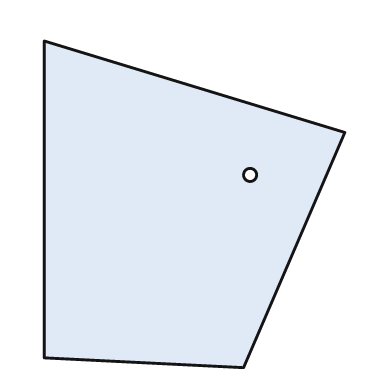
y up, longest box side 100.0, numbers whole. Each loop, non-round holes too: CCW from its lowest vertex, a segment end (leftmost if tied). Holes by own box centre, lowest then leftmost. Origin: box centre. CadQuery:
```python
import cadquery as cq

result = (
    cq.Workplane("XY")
    .moveTo(15.0, -50.0)
    .lineTo(46.0, 22.0)
    .lineTo(-46.0, 50.0)
    .lineTo(-46.0, -47.0)
    .close()
    .moveTo(17.0, 9.0)
    .circle(2.0)
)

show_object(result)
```